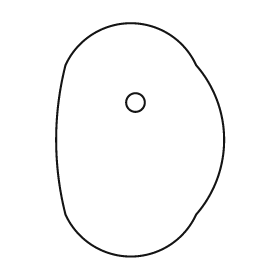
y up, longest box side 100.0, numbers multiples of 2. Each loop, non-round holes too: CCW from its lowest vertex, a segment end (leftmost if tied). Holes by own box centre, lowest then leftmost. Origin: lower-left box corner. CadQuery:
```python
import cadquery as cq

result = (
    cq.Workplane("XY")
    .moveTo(4.0, 18.0)
    .threePointArc((32.0, 0.0), (60.0, 18.0))
    .threePointArc((72.0, 50.0), (60.0, 82.0))
    .threePointArc((32.0, 100.0), (4.0, 82.0))
    .threePointArc((0.0, 50.0), (4.0, 18.0))
    .close()
    .moveTo(34.0, 66.0)
    .circle(4.0)
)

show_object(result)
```